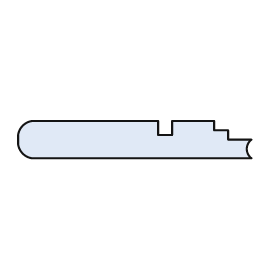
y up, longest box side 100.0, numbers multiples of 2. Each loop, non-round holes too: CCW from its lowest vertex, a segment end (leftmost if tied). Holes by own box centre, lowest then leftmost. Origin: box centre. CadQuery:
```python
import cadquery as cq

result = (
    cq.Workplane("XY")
    .moveTo(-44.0, -8.0)
    .lineTo(50.0, -8.0)
    .threePointArc((48.0, -4.0), (50.0, 0.0))
    .lineTo(40.0, 0.0)
    .lineTo(40.0, 4.0)
    .lineTo(34.0, 4.0)
    .lineTo(34.0, 8.0)
    .lineTo(16.0, 8.0)
    .lineTo(16.0, 2.0)
    .lineTo(10.0, 2.0)
    .lineTo(10.0, 8.0)
    .lineTo(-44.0, 8.0)
    .threePointArc((-48.0, 6.0), (-50.0, 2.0))
    .lineTo(-50.0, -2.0)
    .threePointArc((-48.0, -6.0), (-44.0, -8.0))
    .close()
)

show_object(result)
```